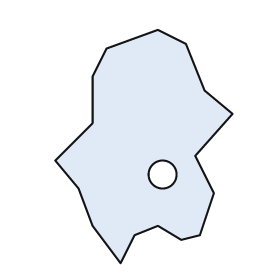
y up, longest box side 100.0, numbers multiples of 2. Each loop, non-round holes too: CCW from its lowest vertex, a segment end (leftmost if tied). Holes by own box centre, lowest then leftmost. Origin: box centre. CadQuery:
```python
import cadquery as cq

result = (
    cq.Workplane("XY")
    .moveTo(-10.0, -50.0)
    .lineTo(-4.0, -38.0)
    .lineTo(6.0, -34.0)
    .lineTo(16.0, -40.0)
    .lineTo(24.0, -38.0)
    .lineTo(30.0, -20.0)
    .lineTo(22.0, -4.0)
    .lineTo(38.0, 14.0)
    .lineTo(26.0, 24.0)
    .lineTo(18.0, 44.0)
    .lineTo(6.0, 50.0)
    .lineTo(-16.0, 42.0)
    .lineTo(-22.0, 30.0)
    .lineTo(-22.0, 10.0)
    .lineTo(-38.0, -6.0)
    .lineTo(-28.0, -18.0)
    .lineTo(-22.0, -34.0)
    .close()
    .moveTo(8.0, -12.0)
    .circle(6.0)
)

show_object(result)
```